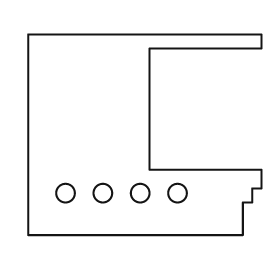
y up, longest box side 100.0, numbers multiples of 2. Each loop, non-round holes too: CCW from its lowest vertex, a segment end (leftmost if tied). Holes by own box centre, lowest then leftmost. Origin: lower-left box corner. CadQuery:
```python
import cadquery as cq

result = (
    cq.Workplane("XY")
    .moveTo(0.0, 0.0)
    .lineTo(92.0, 0.0)
    .lineTo(92.0, 14.0)
    .lineTo(96.0, 14.0)
    .lineTo(96.0, 20.0)
    .lineTo(100.0, 20.0)
    .lineTo(100.0, 28.0)
    .lineTo(52.0, 28.0)
    .lineTo(52.0, 80.0)
    .lineTo(100.0, 80.0)
    .lineTo(100.0, 86.0)
    .lineTo(0.0, 86.0)
    .close()
    .moveTo(16.0, 18.0)
    .circle(4.0)
    .moveTo(32.0, 18.0)
    .circle(4.0)
    .moveTo(48.0, 18.0)
    .circle(4.0)
    .moveTo(64.0, 18.0)
    .circle(4.0)
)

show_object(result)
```